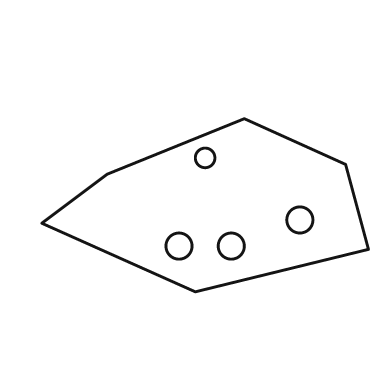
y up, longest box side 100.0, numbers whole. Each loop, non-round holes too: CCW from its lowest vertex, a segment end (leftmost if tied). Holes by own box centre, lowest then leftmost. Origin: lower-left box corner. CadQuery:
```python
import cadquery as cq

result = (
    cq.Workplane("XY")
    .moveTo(47.0, 0.0)
    .lineTo(100.0, 13.0)
    .lineTo(93.0, 39.0)
    .lineTo(62.0, 53.0)
    .lineTo(20.0, 36.0)
    .lineTo(0.0, 21.0)
    .close()
    .moveTo(42.0, 14.0)
    .circle(4.0)
    .moveTo(58.0, 14.0)
    .circle(4.0)
    .moveTo(79.0, 22.0)
    .circle(4.0)
    .moveTo(50.0, 41.0)
    .circle(3.0)
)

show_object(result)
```